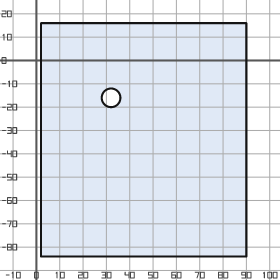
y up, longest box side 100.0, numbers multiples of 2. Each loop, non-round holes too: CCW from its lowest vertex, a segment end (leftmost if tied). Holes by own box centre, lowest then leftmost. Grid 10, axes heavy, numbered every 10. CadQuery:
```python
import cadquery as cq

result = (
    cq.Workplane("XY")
    .moveTo(2.0, -84.0)
    .lineTo(90.0, -84.0)
    .lineTo(90.0, 16.0)
    .lineTo(2.0, 16.0)
    .close()
    .moveTo(32.0, -16.0)
    .circle(4.0)
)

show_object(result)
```